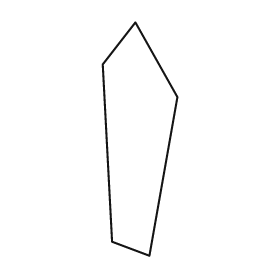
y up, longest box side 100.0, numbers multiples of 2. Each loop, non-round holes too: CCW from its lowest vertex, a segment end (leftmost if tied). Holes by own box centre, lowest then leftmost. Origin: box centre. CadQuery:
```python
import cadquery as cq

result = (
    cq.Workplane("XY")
    .moveTo(4.0, -50.0)
    .lineTo(16.0, 18.0)
    .lineTo(-2.0, 50.0)
    .lineTo(-16.0, 32.0)
    .lineTo(-12.0, -44.0)
    .close()
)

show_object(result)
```